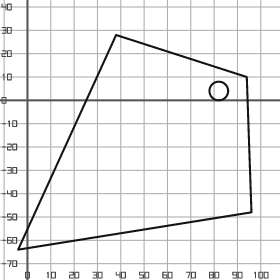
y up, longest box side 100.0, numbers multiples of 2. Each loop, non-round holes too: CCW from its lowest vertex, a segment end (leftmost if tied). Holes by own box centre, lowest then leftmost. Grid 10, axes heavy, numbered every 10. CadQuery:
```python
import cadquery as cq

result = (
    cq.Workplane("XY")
    .moveTo(-4.0, -64.0)
    .lineTo(96.0, -48.0)
    .lineTo(94.0, 10.0)
    .lineTo(38.0, 28.0)
    .close()
    .moveTo(82.0, 4.0)
    .circle(4.0)
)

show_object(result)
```